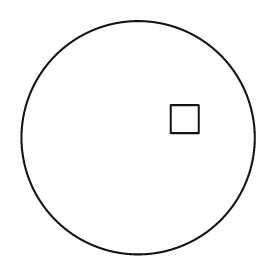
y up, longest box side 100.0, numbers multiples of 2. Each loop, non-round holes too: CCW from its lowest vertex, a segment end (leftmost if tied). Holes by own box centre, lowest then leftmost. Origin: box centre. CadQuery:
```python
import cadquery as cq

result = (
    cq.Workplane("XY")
    .moveTo(0.0, 0.0)
    .circle(50.0)
    .moveTo(14.0, 2.0)
    .lineTo(26.0, 2.0)
    .lineTo(26.0, 14.0)
    .lineTo(14.0, 14.0)
    .close()
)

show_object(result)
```